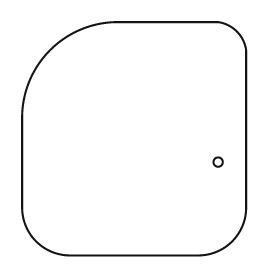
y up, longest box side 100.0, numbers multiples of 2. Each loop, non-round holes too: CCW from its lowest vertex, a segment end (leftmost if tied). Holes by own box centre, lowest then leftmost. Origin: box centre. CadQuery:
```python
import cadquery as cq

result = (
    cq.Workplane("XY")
    .moveTo(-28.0, -50.0)
    .lineTo(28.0, -50.0)
    .threePointArc((42.0, -44.0), (48.0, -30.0))
    .lineTo(48.0, 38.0)
    .threePointArc((44.0, 46.0), (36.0, 50.0))
    .lineTo(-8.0, 50.0)
    .threePointArc((-36.0, 38.0), (-48.0, 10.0))
    .lineTo(-48.0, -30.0)
    .threePointArc((-42.0, -44.0), (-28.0, -50.0))
    .close()
    .moveTo(36.0, -10.0)
    .circle(2.0)
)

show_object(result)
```